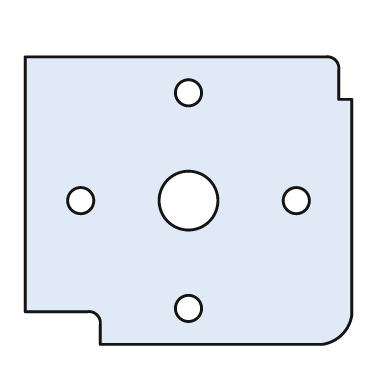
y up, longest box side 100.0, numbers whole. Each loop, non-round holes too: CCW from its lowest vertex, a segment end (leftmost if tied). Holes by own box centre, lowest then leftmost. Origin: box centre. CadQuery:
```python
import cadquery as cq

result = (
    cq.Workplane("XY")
    .moveTo(-27.0, -44.0)
    .lineTo(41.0, -44.0)
    .threePointArc((47.0, -41.0), (50.0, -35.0))
    .lineTo(50.0, 31.0)
    .lineTo(46.0, 31.0)
    .lineTo(46.0, 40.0)
    .threePointArc((45.0, 43.0), (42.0, 44.0))
    .lineTo(-50.0, 44.0)
    .lineTo(-50.0, -34.0)
    .lineTo(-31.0, -34.0)
    .threePointArc((-28.0, -35.0), (-27.0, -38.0))
    .close()
    .moveTo(0.0, -33.0)
    .circle(4.0)
    .moveTo(-33.0, 0.0)
    .circle(4.0)
    .moveTo(0.0, 0.0)
    .circle(9.0)
    .moveTo(33.0, 0.0)
    .circle(4.0)
    .moveTo(0.0, 33.0)
    .circle(4.0)
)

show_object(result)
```